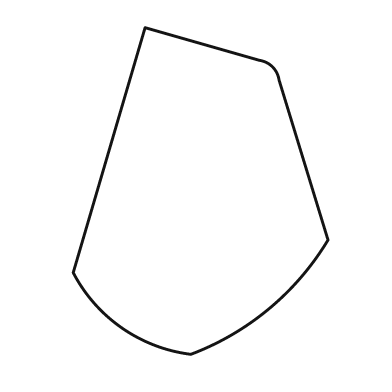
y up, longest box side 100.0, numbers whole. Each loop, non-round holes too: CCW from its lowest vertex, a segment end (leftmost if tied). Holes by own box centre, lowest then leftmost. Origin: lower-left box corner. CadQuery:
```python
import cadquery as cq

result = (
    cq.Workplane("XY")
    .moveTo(36.0, 0.0)
    .threePointArc((60.0, 14.0), (78.0, 35.0))
    .lineTo(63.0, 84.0)
    .threePointArc((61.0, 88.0), (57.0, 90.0))
    .lineTo(22.0, 100.0)
    .lineTo(0.0, 25.0)
    .threePointArc((15.0, 8.0), (36.0, 0.0))
    .close()
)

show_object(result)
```